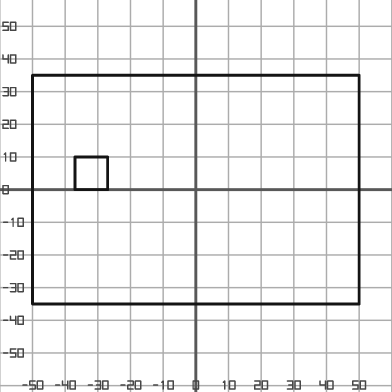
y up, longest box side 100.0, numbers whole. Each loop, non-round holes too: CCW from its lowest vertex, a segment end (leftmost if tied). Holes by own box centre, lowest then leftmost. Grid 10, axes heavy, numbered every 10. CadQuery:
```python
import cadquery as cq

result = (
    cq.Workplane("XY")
    .moveTo(-50.0, -35.0)
    .lineTo(50.0, -35.0)
    .lineTo(50.0, 35.0)
    .lineTo(-50.0, 35.0)
    .close()
    .moveTo(-37.0, 0.0)
    .lineTo(-27.0, 0.0)
    .lineTo(-27.0, 10.0)
    .lineTo(-37.0, 10.0)
    .close()
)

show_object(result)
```